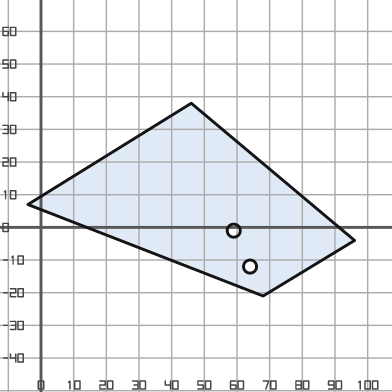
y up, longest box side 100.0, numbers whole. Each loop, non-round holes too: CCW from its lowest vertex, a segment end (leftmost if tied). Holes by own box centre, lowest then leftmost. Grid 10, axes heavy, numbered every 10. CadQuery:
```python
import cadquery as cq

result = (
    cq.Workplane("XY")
    .moveTo(68.0, -21.0)
    .lineTo(96.0, -4.0)
    .lineTo(46.0, 38.0)
    .lineTo(-4.0, 7.0)
    .close()
    .moveTo(64.0, -12.0)
    .circle(2.0)
    .moveTo(59.0, -1.0)
    .circle(2.0)
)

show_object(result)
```